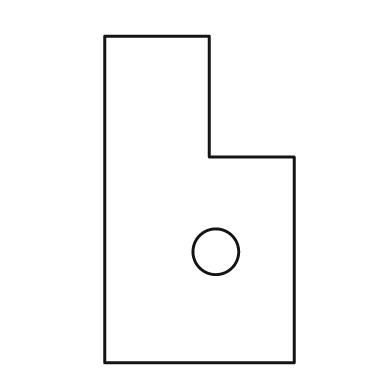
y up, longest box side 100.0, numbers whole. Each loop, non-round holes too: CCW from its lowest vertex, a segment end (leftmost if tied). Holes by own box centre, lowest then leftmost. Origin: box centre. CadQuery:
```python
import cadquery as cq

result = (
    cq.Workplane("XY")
    .moveTo(-29.0, -50.0)
    .lineTo(29.0, -50.0)
    .lineTo(29.0, 13.0)
    .lineTo(3.0, 13.0)
    .lineTo(3.0, 50.0)
    .lineTo(-29.0, 50.0)
    .close()
    .moveTo(5.0, -16.0)
    .circle(7.0)
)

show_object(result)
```